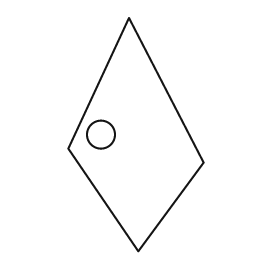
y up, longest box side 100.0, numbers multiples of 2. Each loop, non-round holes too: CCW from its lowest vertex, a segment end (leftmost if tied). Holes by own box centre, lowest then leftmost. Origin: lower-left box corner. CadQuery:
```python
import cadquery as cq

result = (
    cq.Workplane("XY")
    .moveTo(30.0, 0.0)
    .lineTo(58.0, 38.0)
    .lineTo(26.0, 100.0)
    .lineTo(0.0, 44.0)
    .close()
    .moveTo(14.0, 50.0)
    .circle(6.0)
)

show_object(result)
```